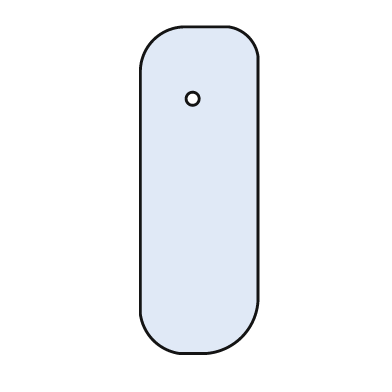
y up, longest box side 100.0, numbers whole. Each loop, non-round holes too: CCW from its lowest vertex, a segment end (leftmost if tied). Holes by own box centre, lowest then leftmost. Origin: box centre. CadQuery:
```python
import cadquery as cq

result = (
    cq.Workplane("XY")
    .moveTo(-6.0, -50.0)
    .lineTo(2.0, -50.0)
    .threePointArc((13.0, -45.0), (18.0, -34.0))
    .lineTo(18.0, 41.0)
    .threePointArc((15.0, 47.0), (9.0, 50.0))
    .lineTo(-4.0, 50.0)
    .threePointArc((-14.0, 46.0), (-18.0, 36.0))
    .lineTo(-18.0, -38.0)
    .threePointArc((-14.0, -46.0), (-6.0, -50.0))
    .close()
    .moveTo(-2.0, 28.0)
    .circle(2.0)
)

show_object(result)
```